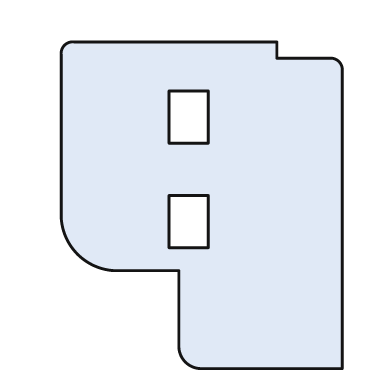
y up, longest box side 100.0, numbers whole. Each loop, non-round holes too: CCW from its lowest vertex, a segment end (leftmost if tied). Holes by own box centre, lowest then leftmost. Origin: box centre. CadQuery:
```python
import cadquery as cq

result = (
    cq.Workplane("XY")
    .moveTo(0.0, -50.0)
    .lineTo(43.0, -50.0)
    .lineTo(43.0, 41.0)
    .threePointArc((42.0, 44.0), (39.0, 45.0))
    .lineTo(23.0, 45.0)
    .lineTo(23.0, 50.0)
    .lineTo(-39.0, 50.0)
    .threePointArc((-42.0, 49.0), (-43.0, 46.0))
    .lineTo(-43.0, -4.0)
    .threePointArc((-38.0, -15.0), (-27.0, -20.0))
    .lineTo(-7.0, -20.0)
    .lineTo(-7.0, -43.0)
    .threePointArc((-5.0, -48.0), (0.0, -50.0))
    .close()
    .moveTo(-10.0, -13.0)
    .lineTo(2.0, -13.0)
    .lineTo(2.0, 3.0)
    .lineTo(-10.0, 3.0)
    .close()
    .moveTo(-10.0, 19.0)
    .lineTo(2.0, 19.0)
    .lineTo(2.0, 35.0)
    .lineTo(-10.0, 35.0)
    .close()
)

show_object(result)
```